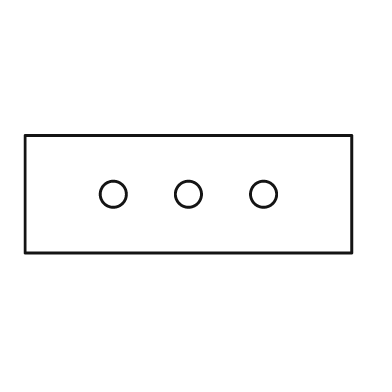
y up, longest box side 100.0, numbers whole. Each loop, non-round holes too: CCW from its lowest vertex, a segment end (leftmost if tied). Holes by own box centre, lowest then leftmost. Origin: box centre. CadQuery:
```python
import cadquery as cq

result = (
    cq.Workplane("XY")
    .moveTo(-50.0, -18.0)
    .lineTo(50.0, -18.0)
    .lineTo(50.0, 18.0)
    .lineTo(-50.0, 18.0)
    .close()
    .moveTo(-23.0, 0.0)
    .circle(4.0)
    .moveTo(0.0, 0.0)
    .circle(4.0)
    .moveTo(23.0, 0.0)
    .circle(4.0)
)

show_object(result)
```